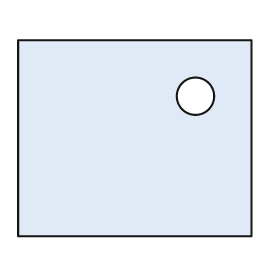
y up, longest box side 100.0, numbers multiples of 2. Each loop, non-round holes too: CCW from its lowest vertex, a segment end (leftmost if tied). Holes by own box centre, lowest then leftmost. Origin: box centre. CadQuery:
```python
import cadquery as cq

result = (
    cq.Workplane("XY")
    .moveTo(-50.0, -42.0)
    .lineTo(50.0, -42.0)
    .lineTo(50.0, 42.0)
    .lineTo(-50.0, 42.0)
    .close()
    .moveTo(26.0, 18.0)
    .circle(8.0)
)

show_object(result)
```